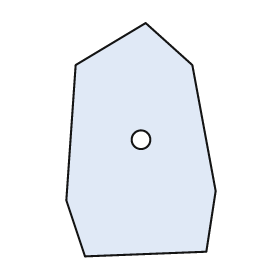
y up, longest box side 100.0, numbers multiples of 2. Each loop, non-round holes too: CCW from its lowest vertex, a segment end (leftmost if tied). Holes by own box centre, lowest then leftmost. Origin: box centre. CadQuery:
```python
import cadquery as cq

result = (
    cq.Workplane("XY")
    .moveTo(-24.0, -50.0)
    .lineTo(28.0, -48.0)
    .lineTo(32.0, -22.0)
    .lineTo(22.0, 32.0)
    .lineTo(2.0, 50.0)
    .lineTo(-28.0, 32.0)
    .lineTo(-32.0, -26.0)
    .close()
    .moveTo(0.0, 0.0)
    .circle(4.0)
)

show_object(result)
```